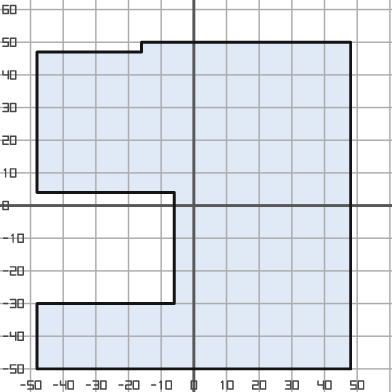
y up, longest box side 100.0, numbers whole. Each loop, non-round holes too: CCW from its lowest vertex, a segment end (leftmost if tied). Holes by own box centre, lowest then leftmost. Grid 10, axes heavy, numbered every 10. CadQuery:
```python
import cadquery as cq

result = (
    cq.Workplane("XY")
    .moveTo(-48.0, -50.0)
    .lineTo(48.0, -50.0)
    .lineTo(48.0, 50.0)
    .lineTo(-16.0, 50.0)
    .lineTo(-16.0, 47.0)
    .lineTo(-48.0, 47.0)
    .lineTo(-48.0, 4.0)
    .lineTo(-6.0, 4.0)
    .lineTo(-6.0, -30.0)
    .lineTo(-48.0, -30.0)
    .close()
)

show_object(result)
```